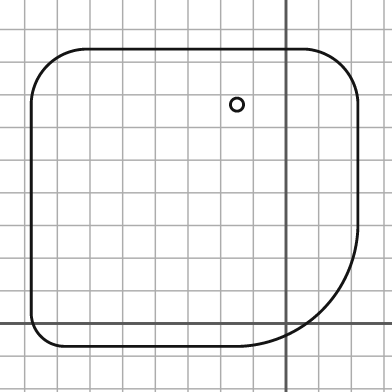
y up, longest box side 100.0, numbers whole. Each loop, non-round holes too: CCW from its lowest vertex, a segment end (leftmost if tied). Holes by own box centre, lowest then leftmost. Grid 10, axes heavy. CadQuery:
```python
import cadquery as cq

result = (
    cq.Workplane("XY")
    .moveTo(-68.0, -7.0)
    .lineTo(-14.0, -7.0)
    .threePointArc((11.0, 4.0), (22.0, 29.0))
    .lineTo(22.0, 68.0)
    .threePointArc((17.0, 79.0), (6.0, 84.0))
    .lineTo(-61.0, 84.0)
    .threePointArc((-73.0, 79.0), (-78.0, 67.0))
    .lineTo(-78.0, 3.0)
    .threePointArc((-75.0, -4.0), (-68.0, -7.0))
    .close()
    .moveTo(-15.0, 67.0)
    .circle(2.0)
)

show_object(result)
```